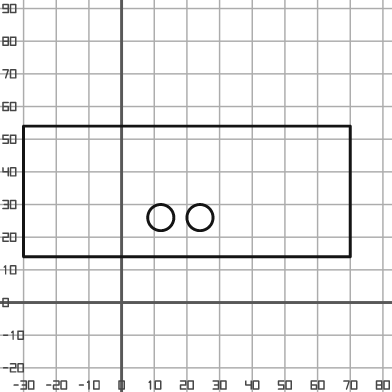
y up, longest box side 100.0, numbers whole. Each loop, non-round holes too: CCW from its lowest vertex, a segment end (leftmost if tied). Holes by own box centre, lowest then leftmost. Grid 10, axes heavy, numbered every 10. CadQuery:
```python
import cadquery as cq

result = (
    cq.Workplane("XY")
    .moveTo(-30.0, 14.0)
    .lineTo(70.0, 14.0)
    .lineTo(70.0, 54.0)
    .lineTo(-30.0, 54.0)
    .close()
    .moveTo(12.0, 26.0)
    .circle(4.0)
    .moveTo(24.0, 26.0)
    .circle(4.0)
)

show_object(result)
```